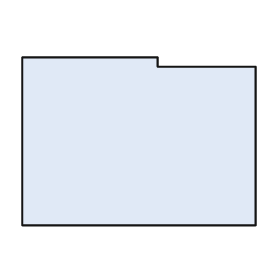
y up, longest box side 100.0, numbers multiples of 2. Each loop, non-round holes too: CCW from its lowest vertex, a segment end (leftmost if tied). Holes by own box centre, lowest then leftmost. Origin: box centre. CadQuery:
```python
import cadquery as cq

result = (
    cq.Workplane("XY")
    .moveTo(-50.0, -36.0)
    .lineTo(50.0, -36.0)
    .lineTo(50.0, 32.0)
    .lineTo(8.0, 32.0)
    .lineTo(8.0, 36.0)
    .lineTo(-50.0, 36.0)
    .close()
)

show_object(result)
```